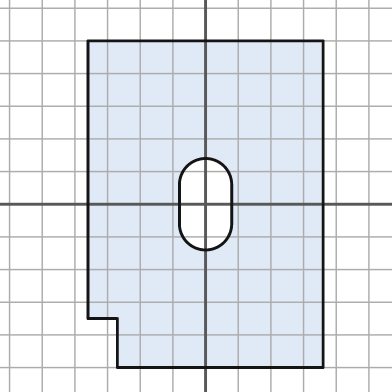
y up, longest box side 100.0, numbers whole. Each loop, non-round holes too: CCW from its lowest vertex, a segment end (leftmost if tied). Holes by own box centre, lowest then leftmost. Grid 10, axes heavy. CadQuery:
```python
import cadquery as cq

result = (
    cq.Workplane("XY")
    .moveTo(-27.0, -50.0)
    .lineTo(36.0, -50.0)
    .lineTo(36.0, 50.0)
    .lineTo(-36.0, 50.0)
    .lineTo(-36.0, -35.0)
    .lineTo(-27.0, -35.0)
    .close()
    .moveTo(-8.0, -6.0)
    .threePointArc((0.0, -14.0), (8.0, -6.0))
    .lineTo(8.0, 6.0)
    .threePointArc((0.0, 14.0), (-8.0, 6.0))
    .close()
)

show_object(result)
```